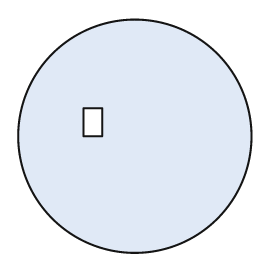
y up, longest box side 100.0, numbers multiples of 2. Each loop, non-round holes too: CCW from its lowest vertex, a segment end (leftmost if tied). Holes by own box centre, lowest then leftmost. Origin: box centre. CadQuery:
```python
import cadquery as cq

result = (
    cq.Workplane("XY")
    .moveTo(0.0, 0.0)
    .circle(50.0)
    .moveTo(-22.0, 0.0)
    .lineTo(-14.0, 0.0)
    .lineTo(-14.0, 12.0)
    .lineTo(-22.0, 12.0)
    .close()
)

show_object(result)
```